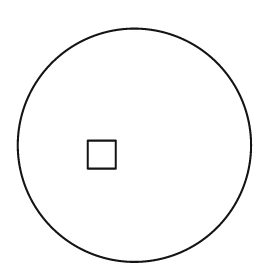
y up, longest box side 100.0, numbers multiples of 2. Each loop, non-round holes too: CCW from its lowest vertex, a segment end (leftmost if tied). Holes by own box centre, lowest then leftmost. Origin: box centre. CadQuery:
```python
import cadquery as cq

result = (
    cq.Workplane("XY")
    .moveTo(0.0, 0.0)
    .circle(50.0)
    .moveTo(-20.0, -10.0)
    .lineTo(-8.0, -10.0)
    .lineTo(-8.0, 2.0)
    .lineTo(-20.0, 2.0)
    .close()
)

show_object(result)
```